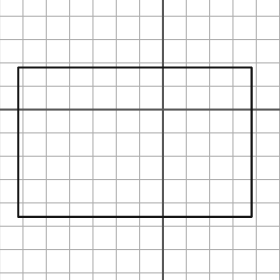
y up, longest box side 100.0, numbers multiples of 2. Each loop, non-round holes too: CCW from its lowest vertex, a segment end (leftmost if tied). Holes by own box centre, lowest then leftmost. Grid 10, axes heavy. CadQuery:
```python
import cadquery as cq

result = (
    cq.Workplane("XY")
    .moveTo(-62.0, -46.0)
    .lineTo(38.0, -46.0)
    .lineTo(38.0, 18.0)
    .lineTo(-62.0, 18.0)
    .close()
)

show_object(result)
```